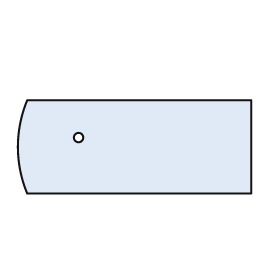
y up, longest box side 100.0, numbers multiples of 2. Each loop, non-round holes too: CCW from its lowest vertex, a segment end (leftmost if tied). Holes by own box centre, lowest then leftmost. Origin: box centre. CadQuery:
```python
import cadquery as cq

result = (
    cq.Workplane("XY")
    .moveTo(-46.0, -20.0)
    .lineTo(50.0, -20.0)
    .lineTo(50.0, 20.0)
    .lineTo(-46.0, 20.0)
    .threePointArc((-50.0, 0.0), (-46.0, -20.0))
    .close()
    .moveTo(-24.0, 4.0)
    .circle(2.0)
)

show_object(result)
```